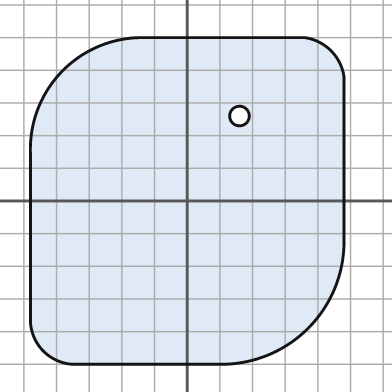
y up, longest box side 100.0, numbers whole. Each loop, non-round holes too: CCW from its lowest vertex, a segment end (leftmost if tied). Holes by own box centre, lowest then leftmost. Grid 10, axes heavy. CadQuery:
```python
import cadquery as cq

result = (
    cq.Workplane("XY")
    .moveTo(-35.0, -50.0)
    .lineTo(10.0, -50.0)
    .threePointArc((37.0, -39.0), (48.0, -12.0))
    .lineTo(48.0, 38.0)
    .threePointArc((44.0, 46.0), (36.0, 50.0))
    .lineTo(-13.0, 50.0)
    .threePointArc((-38.0, 40.0), (-48.0, 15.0))
    .lineTo(-48.0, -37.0)
    .threePointArc((-44.0, -46.0), (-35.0, -50.0))
    .close()
    .moveTo(16.0, 26.0)
    .circle(3.0)
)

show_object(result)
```